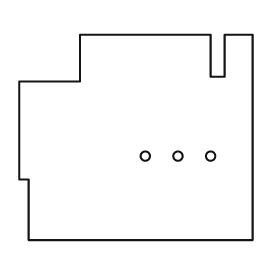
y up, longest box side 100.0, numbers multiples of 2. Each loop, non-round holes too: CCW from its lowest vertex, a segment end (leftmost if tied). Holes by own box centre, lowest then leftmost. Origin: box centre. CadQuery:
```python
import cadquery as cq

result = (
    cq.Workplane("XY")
    .moveTo(-46.0, -44.0)
    .lineTo(50.0, -44.0)
    .lineTo(50.0, 44.0)
    .lineTo(38.0, 44.0)
    .lineTo(38.0, 26.0)
    .lineTo(32.0, 26.0)
    .lineTo(32.0, 44.0)
    .lineTo(-24.0, 44.0)
    .lineTo(-24.0, 24.0)
    .lineTo(-50.0, 24.0)
    .lineTo(-50.0, -18.0)
    .lineTo(-46.0, -18.0)
    .close()
    .moveTo(4.0, -8.0)
    .circle(2.0)
    .moveTo(18.0, -8.0)
    .circle(2.0)
    .moveTo(32.0, -8.0)
    .circle(2.0)
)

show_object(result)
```